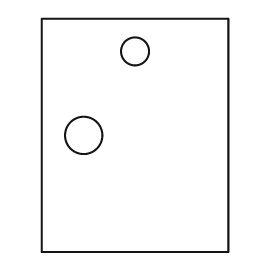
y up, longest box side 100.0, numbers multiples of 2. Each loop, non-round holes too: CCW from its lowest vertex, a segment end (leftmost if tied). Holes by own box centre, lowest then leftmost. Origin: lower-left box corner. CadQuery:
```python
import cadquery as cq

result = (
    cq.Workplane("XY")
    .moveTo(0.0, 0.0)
    .lineTo(80.0, 0.0)
    .lineTo(80.0, 100.0)
    .lineTo(0.0, 100.0)
    .close()
    .moveTo(18.0, 50.0)
    .circle(8.0)
    .moveTo(40.0, 86.0)
    .circle(6.0)
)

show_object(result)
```